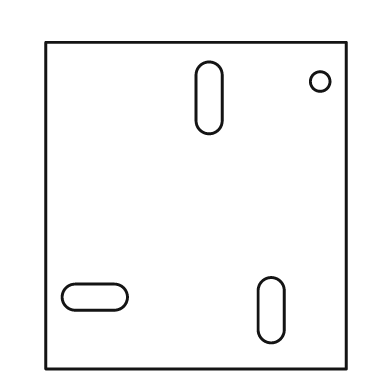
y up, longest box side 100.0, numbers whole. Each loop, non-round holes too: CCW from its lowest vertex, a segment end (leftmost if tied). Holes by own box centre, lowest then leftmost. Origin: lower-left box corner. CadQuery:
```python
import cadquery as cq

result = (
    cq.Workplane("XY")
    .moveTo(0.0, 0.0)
    .lineTo(92.0, 0.0)
    .lineTo(92.0, 100.0)
    .lineTo(0.0, 100.0)
    .close()
    .moveTo(65.0, 12.0)
    .threePointArc((69.0, 8.0), (73.0, 12.0))
    .lineTo(73.0, 24.0)
    .threePointArc((69.0, 28.0), (65.0, 24.0))
    .close()
    .moveTo(9.0, 18.0)
    .lineTo(21.0, 18.0)
    .threePointArc((25.0, 22.0), (21.0, 26.0))
    .lineTo(9.0, 26.0)
    .threePointArc((5.0, 22.0), (9.0, 18.0))
    .close()
    .moveTo(46.0, 76.0)
    .threePointArc((50.0, 72.0), (54.0, 76.0))
    .lineTo(54.0, 90.0)
    .threePointArc((50.0, 94.0), (46.0, 90.0))
    .close()
    .moveTo(84.0, 88.0)
    .circle(3.0)
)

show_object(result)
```